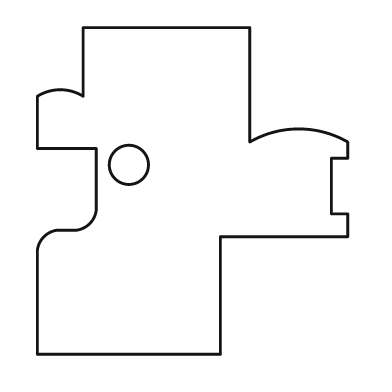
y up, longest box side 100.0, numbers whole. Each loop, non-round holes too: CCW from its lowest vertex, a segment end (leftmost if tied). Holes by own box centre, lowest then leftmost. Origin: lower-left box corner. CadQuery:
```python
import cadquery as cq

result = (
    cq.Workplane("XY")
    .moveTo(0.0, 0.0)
    .lineTo(56.0, 0.0)
    .lineTo(56.0, 36.0)
    .lineTo(95.0, 36.0)
    .lineTo(95.0, 43.0)
    .lineTo(90.0, 43.0)
    .lineTo(90.0, 60.0)
    .lineTo(95.0, 60.0)
    .lineTo(95.0, 65.0)
    .threePointArc((80.0, 69.0), (65.0, 65.0))
    .lineTo(65.0, 100.0)
    .lineTo(14.0, 100.0)
    .lineTo(14.0, 79.0)
    .threePointArc((7.0, 81.0), (0.0, 79.0))
    .lineTo(0.0, 63.0)
    .lineTo(18.0, 63.0)
    .lineTo(18.0, 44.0)
    .threePointArc((16.0, 40.0), (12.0, 38.0))
    .lineTo(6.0, 38.0)
    .threePointArc((2.0, 36.0), (0.0, 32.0))
    .close()
    .moveTo(28.0, 58.0)
    .circle(6.0)
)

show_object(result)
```